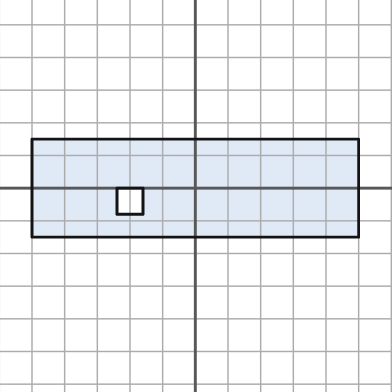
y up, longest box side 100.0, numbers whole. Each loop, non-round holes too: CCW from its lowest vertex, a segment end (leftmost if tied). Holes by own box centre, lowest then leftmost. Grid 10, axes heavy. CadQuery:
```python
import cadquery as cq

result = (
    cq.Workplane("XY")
    .moveTo(-50.0, -15.0)
    .lineTo(50.0, -15.0)
    .lineTo(50.0, 15.0)
    .lineTo(-50.0, 15.0)
    .close()
    .moveTo(-24.0, -8.0)
    .lineTo(-16.0, -8.0)
    .lineTo(-16.0, 0.0)
    .lineTo(-24.0, 0.0)
    .close()
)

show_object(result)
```